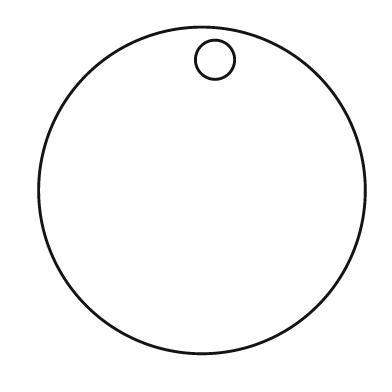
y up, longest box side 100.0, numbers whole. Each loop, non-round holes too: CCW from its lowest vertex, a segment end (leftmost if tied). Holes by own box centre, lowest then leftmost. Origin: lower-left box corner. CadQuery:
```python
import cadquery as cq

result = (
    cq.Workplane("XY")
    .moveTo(50.0, 50.0)
    .circle(50.0)
    .moveTo(54.0, 90.0)
    .circle(6.0)
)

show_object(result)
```